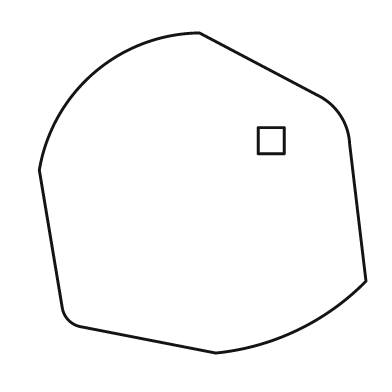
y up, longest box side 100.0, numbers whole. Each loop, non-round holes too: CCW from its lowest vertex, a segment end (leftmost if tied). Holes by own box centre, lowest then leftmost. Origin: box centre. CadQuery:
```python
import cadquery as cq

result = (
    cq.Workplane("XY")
    .moveTo(4.0, -49.0)
    .threePointArc((29.0, -42.0), (50.0, -27.0))
    .lineTo(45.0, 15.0)
    .threePointArc((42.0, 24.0), (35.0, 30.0))
    .lineTo(-1.0, 49.0)
    .threePointArc((-33.0, 37.0), (-50.0, 7.0))
    .lineTo(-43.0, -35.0)
    .threePointArc((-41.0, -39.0), (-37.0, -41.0))
    .close()
    .moveTo(17.0, 12.0)
    .lineTo(25.0, 12.0)
    .lineTo(25.0, 20.0)
    .lineTo(17.0, 20.0)
    .close()
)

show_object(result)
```